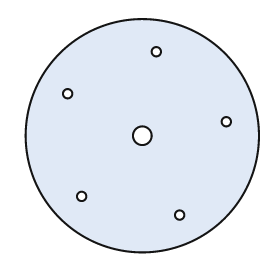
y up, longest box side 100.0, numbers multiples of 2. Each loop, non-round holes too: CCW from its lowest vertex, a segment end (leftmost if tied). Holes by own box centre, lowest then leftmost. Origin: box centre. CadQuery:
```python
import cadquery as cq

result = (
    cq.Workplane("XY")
    .moveTo(0.0, 0.0)
    .circle(50.0)
    .moveTo(16.0, -34.0)
    .circle(2.0)
    .moveTo(-26.0, -26.0)
    .circle(2.0)
    .moveTo(0.0, 0.0)
    .circle(4.0)
    .moveTo(36.0, 6.0)
    .circle(2.0)
    .moveTo(-32.0, 18.0)
    .circle(2.0)
    .moveTo(6.0, 36.0)
    .circle(2.0)
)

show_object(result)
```